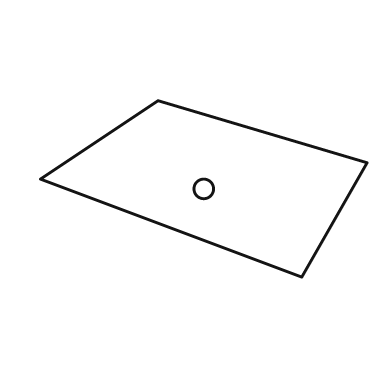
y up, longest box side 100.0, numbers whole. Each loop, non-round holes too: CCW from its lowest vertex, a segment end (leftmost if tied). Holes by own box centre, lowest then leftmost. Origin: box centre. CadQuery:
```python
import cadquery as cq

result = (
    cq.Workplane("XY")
    .moveTo(30.0, -27.0)
    .lineTo(50.0, 8.0)
    .lineTo(-14.0, 27.0)
    .lineTo(-50.0, 3.0)
    .close()
    .moveTo(0.0, 0.0)
    .circle(3.0)
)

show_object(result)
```